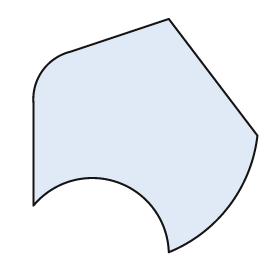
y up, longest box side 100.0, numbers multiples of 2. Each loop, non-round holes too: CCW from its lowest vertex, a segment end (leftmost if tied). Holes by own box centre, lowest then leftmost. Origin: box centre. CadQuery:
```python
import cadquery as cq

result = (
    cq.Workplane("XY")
    .moveTo(10.0, -50.0)
    .threePointArc((36.0, -30.0), (48.0, 0.0))
    .lineTo(10.0, 50.0)
    .lineTo(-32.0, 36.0)
    .threePointArc((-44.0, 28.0), (-48.0, 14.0))
    .lineTo(-48.0, -30.0)
    .threePointArc((-12.0, -20.0), (10.0, -50.0))
    .close()
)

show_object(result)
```